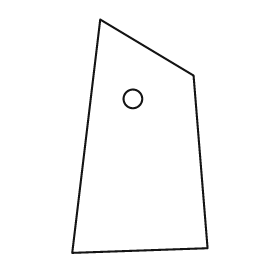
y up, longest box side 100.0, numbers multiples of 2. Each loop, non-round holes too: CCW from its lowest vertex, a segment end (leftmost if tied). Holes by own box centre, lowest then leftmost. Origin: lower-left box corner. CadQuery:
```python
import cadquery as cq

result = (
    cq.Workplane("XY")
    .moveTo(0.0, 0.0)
    .lineTo(58.0, 2.0)
    .lineTo(52.0, 76.0)
    .lineTo(12.0, 100.0)
    .close()
    .moveTo(26.0, 66.0)
    .circle(4.0)
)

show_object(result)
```